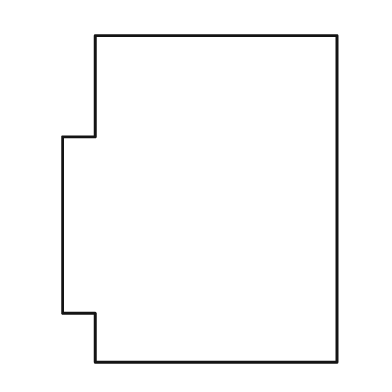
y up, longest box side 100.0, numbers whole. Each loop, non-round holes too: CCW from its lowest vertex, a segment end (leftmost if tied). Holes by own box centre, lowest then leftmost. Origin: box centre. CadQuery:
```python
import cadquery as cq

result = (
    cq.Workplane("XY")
    .moveTo(-32.0, -50.0)
    .lineTo(42.0, -50.0)
    .lineTo(42.0, 50.0)
    .lineTo(-32.0, 50.0)
    .lineTo(-32.0, 19.0)
    .lineTo(-42.0, 19.0)
    .lineTo(-42.0, -35.0)
    .lineTo(-32.0, -35.0)
    .close()
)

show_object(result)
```